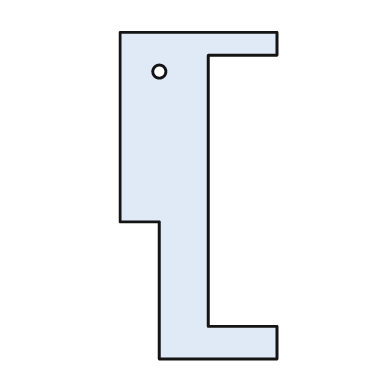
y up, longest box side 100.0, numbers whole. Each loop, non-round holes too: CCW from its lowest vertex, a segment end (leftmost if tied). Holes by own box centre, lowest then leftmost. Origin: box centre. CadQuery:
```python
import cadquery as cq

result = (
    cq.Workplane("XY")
    .moveTo(-12.0, -50.0)
    .lineTo(24.0, -50.0)
    .lineTo(24.0, -40.0)
    .lineTo(3.0, -40.0)
    .lineTo(3.0, 43.0)
    .lineTo(24.0, 43.0)
    .lineTo(24.0, 50.0)
    .lineTo(-24.0, 50.0)
    .lineTo(-24.0, -8.0)
    .lineTo(-12.0, -8.0)
    .close()
    .moveTo(-12.0, 38.0)
    .circle(2.0)
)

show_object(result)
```